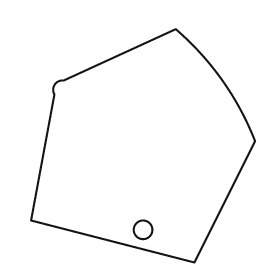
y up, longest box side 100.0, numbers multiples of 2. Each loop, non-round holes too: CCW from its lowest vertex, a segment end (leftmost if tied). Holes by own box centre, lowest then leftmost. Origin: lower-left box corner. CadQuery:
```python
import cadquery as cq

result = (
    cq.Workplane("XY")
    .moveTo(70.0, 0.0)
    .lineTo(96.0, 52.0)
    .threePointArc((82.0, 78.0), (62.0, 100.0))
    .lineTo(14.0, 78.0)
    .threePointArc((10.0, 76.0), (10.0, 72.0))
    .lineTo(0.0, 18.0)
    .close()
    .moveTo(48.0, 14.0)
    .circle(4.0)
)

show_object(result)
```